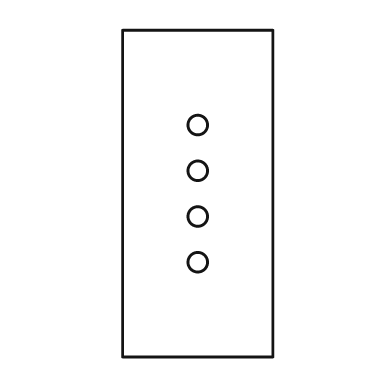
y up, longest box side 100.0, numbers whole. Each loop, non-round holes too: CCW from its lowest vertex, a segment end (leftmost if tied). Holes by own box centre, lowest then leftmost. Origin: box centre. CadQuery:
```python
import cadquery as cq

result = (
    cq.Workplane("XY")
    .moveTo(-23.0, -50.0)
    .lineTo(23.0, -50.0)
    .lineTo(23.0, 50.0)
    .lineTo(-23.0, 50.0)
    .close()
    .moveTo(0.0, -21.0)
    .circle(3.0)
    .moveTo(0.0, -7.0)
    .circle(3.0)
    .moveTo(0.0, 7.0)
    .circle(3.0)
    .moveTo(0.0, 21.0)
    .circle(3.0)
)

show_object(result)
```